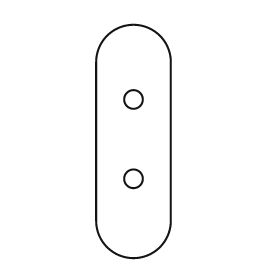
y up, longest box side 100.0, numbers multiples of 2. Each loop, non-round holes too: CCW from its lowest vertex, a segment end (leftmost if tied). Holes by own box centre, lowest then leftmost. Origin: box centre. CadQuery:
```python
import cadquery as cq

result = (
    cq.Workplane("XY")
    .moveTo(-16.0, -34.0)
    .threePointArc((0.0, -50.0), (16.0, -34.0))
    .lineTo(16.0, 34.0)
    .threePointArc((0.0, 50.0), (-16.0, 34.0))
    .close()
    .moveTo(0.0, -16.0)
    .circle(4.0)
    .moveTo(0.0, 18.0)
    .circle(4.0)
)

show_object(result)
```